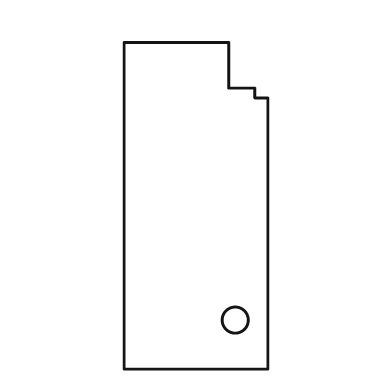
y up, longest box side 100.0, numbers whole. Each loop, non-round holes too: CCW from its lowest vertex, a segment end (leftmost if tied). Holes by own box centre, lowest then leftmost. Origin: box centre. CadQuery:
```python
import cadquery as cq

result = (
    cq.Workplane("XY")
    .moveTo(-22.0, -50.0)
    .lineTo(22.0, -50.0)
    .lineTo(22.0, 33.0)
    .lineTo(18.0, 33.0)
    .lineTo(18.0, 36.0)
    .lineTo(10.0, 36.0)
    .lineTo(10.0, 50.0)
    .lineTo(-22.0, 50.0)
    .close()
    .moveTo(12.0, -35.0)
    .circle(4.0)
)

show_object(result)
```